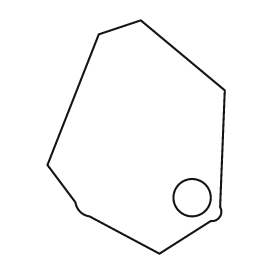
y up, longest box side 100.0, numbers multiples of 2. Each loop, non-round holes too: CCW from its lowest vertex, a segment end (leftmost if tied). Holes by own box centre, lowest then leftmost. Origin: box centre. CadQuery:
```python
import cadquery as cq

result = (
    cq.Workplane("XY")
    .moveTo(10.0, -50.0)
    .lineTo(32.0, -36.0)
    .threePointArc((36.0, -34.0), (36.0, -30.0))
    .lineTo(38.0, 20.0)
    .lineTo(2.0, 50.0)
    .lineTo(-16.0, 44.0)
    .lineTo(-38.0, -12.0)
    .lineTo(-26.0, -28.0)
    .threePointArc((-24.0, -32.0), (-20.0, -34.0))
    .close()
    .moveTo(24.0, -26.0)
    .circle(8.0)
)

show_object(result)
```